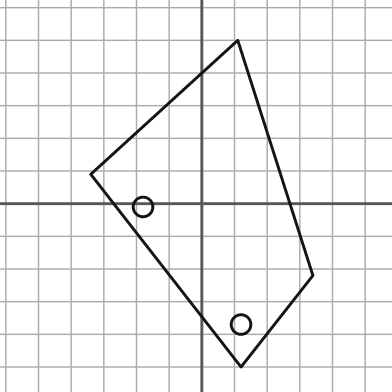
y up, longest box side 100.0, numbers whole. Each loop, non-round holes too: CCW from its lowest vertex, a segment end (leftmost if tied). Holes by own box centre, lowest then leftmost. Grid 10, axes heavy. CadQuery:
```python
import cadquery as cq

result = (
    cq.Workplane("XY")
    .moveTo(12.0, -50.0)
    .lineTo(34.0, -22.0)
    .lineTo(11.0, 50.0)
    .lineTo(-34.0, 9.0)
    .close()
    .moveTo(12.0, -37.0)
    .circle(3.0)
    .moveTo(-18.0, -1.0)
    .circle(3.0)
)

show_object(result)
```